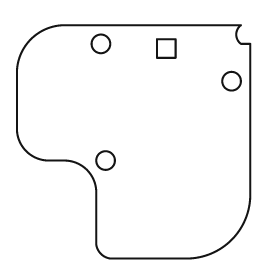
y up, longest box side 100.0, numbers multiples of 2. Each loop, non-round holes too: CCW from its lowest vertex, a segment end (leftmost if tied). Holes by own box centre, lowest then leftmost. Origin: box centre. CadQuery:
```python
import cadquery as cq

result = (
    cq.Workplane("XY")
    .moveTo(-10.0, -50.0)
    .lineTo(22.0, -50.0)
    .threePointArc((42.0, -42.0), (50.0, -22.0))
    .lineTo(50.0, 42.0)
    .lineTo(46.0, 42.0)
    .threePointArc((44.0, 46.0), (46.0, 50.0))
    .lineTo(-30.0, 50.0)
    .threePointArc((-44.0, 44.0), (-50.0, 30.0))
    .lineTo(-50.0, 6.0)
    .threePointArc((-46.0, -4.0), (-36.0, -8.0))
    .lineTo(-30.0, -8.0)
    .threePointArc((-20.0, -12.0), (-16.0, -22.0))
    .lineTo(-16.0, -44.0)
    .threePointArc((-14.0, -48.0), (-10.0, -50.0))
    .close()
    .moveTo(-12.0, -8.0)
    .circle(4.0)
    .moveTo(42.0, 26.0)
    .circle(4.0)
    .moveTo(10.0, 36.0)
    .lineTo(18.0, 36.0)
    .lineTo(18.0, 44.0)
    .lineTo(10.0, 44.0)
    .close()
    .moveTo(-14.0, 42.0)
    .circle(4.0)
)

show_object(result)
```